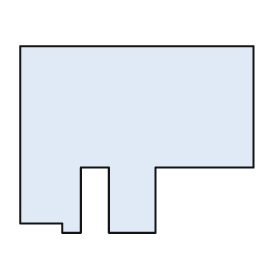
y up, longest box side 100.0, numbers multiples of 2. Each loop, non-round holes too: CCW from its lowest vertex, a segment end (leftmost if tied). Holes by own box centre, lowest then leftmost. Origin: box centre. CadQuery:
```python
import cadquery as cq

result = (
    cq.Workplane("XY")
    .moveTo(-32.0, -40.0)
    .lineTo(-24.0, -40.0)
    .lineTo(-24.0, -12.0)
    .lineTo(-12.0, -12.0)
    .lineTo(-12.0, -40.0)
    .lineTo(8.0, -40.0)
    .lineTo(8.0, -12.0)
    .lineTo(50.0, -12.0)
    .lineTo(50.0, 40.0)
    .lineTo(-50.0, 40.0)
    .lineTo(-50.0, -36.0)
    .lineTo(-32.0, -36.0)
    .close()
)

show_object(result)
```